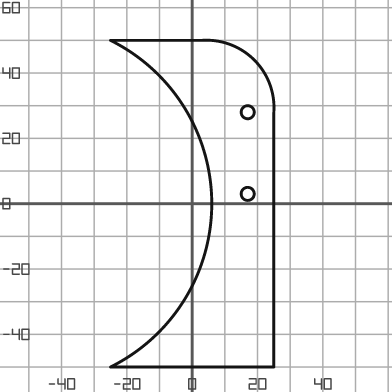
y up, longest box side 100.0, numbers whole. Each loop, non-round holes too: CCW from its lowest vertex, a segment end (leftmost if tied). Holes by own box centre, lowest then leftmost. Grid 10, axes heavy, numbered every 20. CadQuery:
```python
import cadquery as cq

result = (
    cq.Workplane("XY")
    .moveTo(-25.0, -50.0)
    .lineTo(25.0, -50.0)
    .lineTo(25.0, 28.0)
    .threePointArc((19.0, 44.0), (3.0, 50.0))
    .lineTo(-25.0, 50.0)
    .threePointArc((6.0, 0.0), (-25.0, -50.0))
    .close()
    .moveTo(17.0, 3.0)
    .circle(2.0)
    .moveTo(17.0, 28.0)
    .circle(2.0)
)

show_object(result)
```